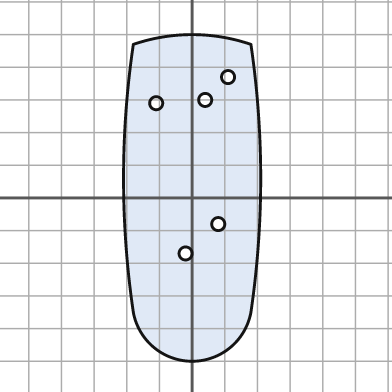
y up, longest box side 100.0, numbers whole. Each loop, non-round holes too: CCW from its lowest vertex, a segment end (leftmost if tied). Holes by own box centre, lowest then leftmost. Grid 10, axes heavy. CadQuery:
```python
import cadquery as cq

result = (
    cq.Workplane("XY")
    .moveTo(-18.0, -35.0)
    .threePointArc((0.0, -50.0), (18.0, -35.0))
    .threePointArc((21.0, 6.0), (18.0, 47.0))
    .threePointArc((0.0, 50.0), (-18.0, 47.0))
    .threePointArc((-21.0, 6.0), (-18.0, -35.0))
    .close()
    .moveTo(-2.0, -17.0)
    .circle(2.0)
    .moveTo(8.0, -8.0)
    .circle(2.0)
    .moveTo(-11.0, 29.0)
    .circle(2.0)
    .moveTo(4.0, 30.0)
    .circle(2.0)
    .moveTo(11.0, 37.0)
    .circle(2.0)
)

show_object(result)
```